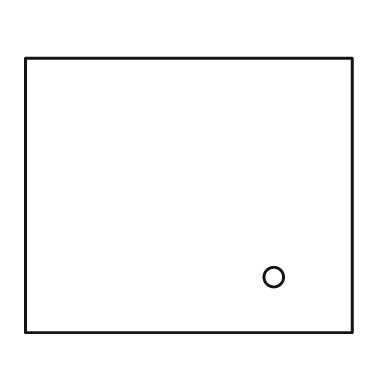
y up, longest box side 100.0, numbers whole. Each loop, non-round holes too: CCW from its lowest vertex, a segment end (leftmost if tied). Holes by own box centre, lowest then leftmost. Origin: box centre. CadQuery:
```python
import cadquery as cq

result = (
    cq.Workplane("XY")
    .moveTo(-50.0, -42.0)
    .lineTo(50.0, -42.0)
    .lineTo(50.0, 42.0)
    .lineTo(-50.0, 42.0)
    .close()
    .moveTo(26.0, -25.0)
    .circle(3.0)
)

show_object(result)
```